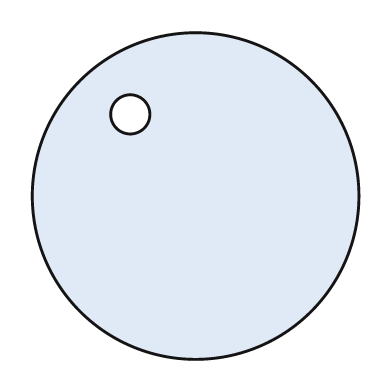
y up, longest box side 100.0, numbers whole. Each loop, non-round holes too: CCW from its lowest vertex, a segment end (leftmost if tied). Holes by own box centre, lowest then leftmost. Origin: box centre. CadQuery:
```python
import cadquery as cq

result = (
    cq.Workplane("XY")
    .moveTo(0.0, 0.0)
    .circle(50.0)
    .moveTo(-20.0, 25.0)
    .circle(6.0)
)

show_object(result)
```